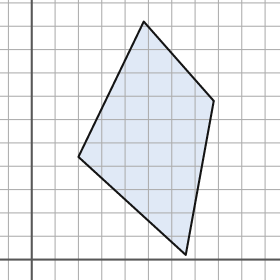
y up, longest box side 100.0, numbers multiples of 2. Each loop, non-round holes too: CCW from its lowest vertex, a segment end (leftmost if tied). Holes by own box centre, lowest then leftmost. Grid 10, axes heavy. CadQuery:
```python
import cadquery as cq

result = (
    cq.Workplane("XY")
    .moveTo(66.0, 2.0)
    .lineTo(78.0, 68.0)
    .lineTo(48.0, 102.0)
    .lineTo(20.0, 44.0)
    .close()
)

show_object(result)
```